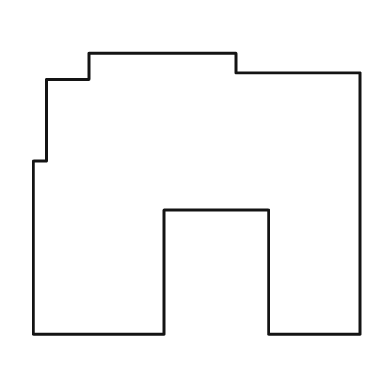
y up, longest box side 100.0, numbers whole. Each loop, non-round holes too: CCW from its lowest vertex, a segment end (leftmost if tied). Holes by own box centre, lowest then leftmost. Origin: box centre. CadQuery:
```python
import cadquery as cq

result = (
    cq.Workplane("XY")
    .moveTo(-50.0, -43.0)
    .lineTo(-10.0, -43.0)
    .lineTo(-10.0, -5.0)
    .lineTo(22.0, -5.0)
    .lineTo(22.0, -43.0)
    .lineTo(50.0, -43.0)
    .lineTo(50.0, 37.0)
    .lineTo(12.0, 37.0)
    .lineTo(12.0, 43.0)
    .lineTo(-33.0, 43.0)
    .lineTo(-33.0, 35.0)
    .lineTo(-46.0, 35.0)
    .lineTo(-46.0, 10.0)
    .lineTo(-50.0, 10.0)
    .close()
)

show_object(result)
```